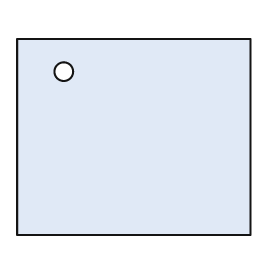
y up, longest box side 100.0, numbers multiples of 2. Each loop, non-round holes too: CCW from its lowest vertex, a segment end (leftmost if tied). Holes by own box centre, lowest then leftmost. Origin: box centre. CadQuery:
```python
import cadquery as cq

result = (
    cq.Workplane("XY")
    .moveTo(-50.0, -42.0)
    .lineTo(50.0, -42.0)
    .lineTo(50.0, 42.0)
    .lineTo(-50.0, 42.0)
    .close()
    .moveTo(-30.0, 28.0)
    .circle(4.0)
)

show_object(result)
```